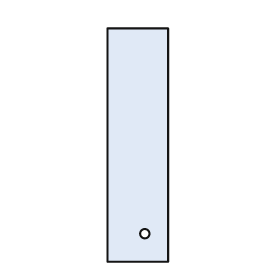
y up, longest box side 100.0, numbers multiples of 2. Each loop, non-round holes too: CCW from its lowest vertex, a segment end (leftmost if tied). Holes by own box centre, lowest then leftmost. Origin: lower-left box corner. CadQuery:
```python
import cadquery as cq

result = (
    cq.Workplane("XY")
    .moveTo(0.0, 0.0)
    .lineTo(26.0, 0.0)
    .lineTo(26.0, 100.0)
    .lineTo(0.0, 100.0)
    .close()
    .moveTo(16.0, 12.0)
    .circle(2.0)
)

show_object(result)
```